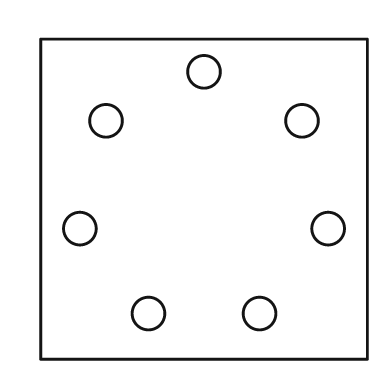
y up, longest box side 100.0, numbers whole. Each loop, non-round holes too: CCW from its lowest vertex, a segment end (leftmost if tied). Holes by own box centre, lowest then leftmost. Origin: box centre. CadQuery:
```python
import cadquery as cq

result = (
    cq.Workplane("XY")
    .moveTo(-50.0, -49.0)
    .lineTo(50.0, -49.0)
    .lineTo(50.0, 49.0)
    .lineTo(-50.0, 49.0)
    .close()
    .moveTo(-17.0, -35.0)
    .circle(5.0)
    .moveTo(17.0, -35.0)
    .circle(5.0)
    .moveTo(-38.0, -9.0)
    .circle(5.0)
    .moveTo(38.0, -9.0)
    .circle(5.0)
    .moveTo(-30.0, 24.0)
    .circle(5.0)
    .moveTo(30.0, 24.0)
    .circle(5.0)
    .moveTo(0.0, 39.0)
    .circle(5.0)
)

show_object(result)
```